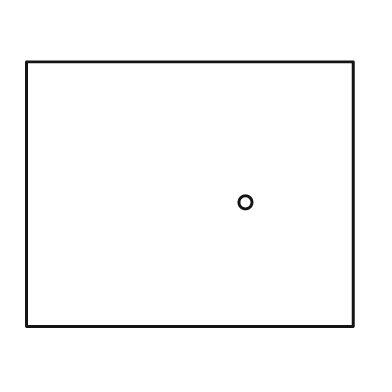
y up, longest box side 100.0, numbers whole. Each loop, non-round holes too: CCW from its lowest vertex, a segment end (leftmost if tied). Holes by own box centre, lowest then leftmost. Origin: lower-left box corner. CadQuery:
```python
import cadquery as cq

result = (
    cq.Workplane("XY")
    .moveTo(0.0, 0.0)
    .lineTo(100.0, 0.0)
    .lineTo(100.0, 81.0)
    .lineTo(0.0, 81.0)
    .close()
    .moveTo(67.0, 38.0)
    .circle(2.0)
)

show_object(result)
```